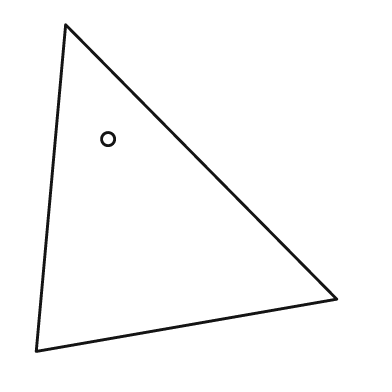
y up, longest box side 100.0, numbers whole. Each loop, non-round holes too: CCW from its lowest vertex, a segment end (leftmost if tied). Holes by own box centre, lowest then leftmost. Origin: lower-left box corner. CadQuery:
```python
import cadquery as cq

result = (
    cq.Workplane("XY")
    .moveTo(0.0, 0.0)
    .lineTo(92.0, 16.0)
    .lineTo(9.0, 100.0)
    .close()
    .moveTo(22.0, 65.0)
    .circle(2.0)
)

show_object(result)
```